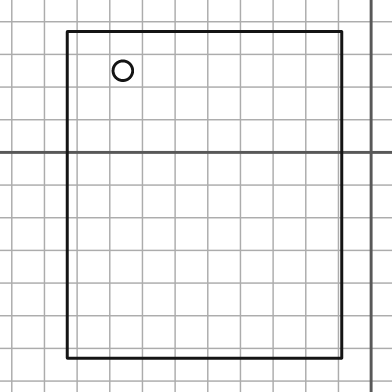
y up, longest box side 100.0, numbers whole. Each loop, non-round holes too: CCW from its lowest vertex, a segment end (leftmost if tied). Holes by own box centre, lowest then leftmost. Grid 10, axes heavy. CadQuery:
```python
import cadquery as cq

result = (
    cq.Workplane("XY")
    .moveTo(-93.0, -63.0)
    .lineTo(-9.0, -63.0)
    .lineTo(-9.0, 37.0)
    .lineTo(-93.0, 37.0)
    .close()
    .moveTo(-76.0, 25.0)
    .circle(3.0)
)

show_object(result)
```